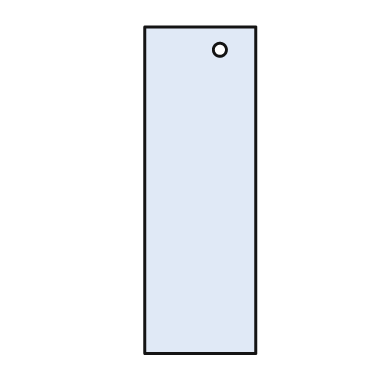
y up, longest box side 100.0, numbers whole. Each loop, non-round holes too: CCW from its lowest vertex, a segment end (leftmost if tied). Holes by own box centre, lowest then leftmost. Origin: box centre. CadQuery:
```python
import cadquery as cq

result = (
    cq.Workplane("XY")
    .moveTo(-17.0, -50.0)
    .lineTo(17.0, -50.0)
    .lineTo(17.0, 50.0)
    .lineTo(-17.0, 50.0)
    .close()
    .moveTo(6.0, 43.0)
    .circle(2.0)
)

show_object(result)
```